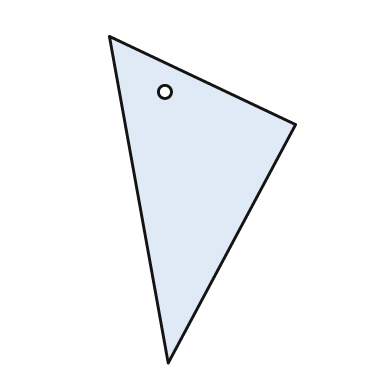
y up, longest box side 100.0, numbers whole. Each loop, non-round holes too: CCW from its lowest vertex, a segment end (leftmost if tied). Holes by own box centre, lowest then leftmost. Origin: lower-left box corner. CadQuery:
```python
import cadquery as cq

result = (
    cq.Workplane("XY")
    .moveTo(18.0, 0.0)
    .lineTo(57.0, 73.0)
    .lineTo(0.0, 100.0)
    .close()
    .moveTo(17.0, 83.0)
    .circle(2.0)
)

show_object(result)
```